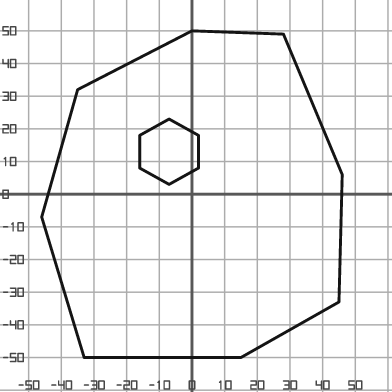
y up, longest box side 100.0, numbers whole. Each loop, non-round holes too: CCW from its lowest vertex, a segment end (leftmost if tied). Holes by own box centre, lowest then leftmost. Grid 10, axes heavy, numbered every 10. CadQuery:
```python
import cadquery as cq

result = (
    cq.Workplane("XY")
    .moveTo(-33.0, -50.0)
    .lineTo(15.0, -50.0)
    .lineTo(45.0, -33.0)
    .lineTo(46.0, 6.0)
    .lineTo(28.0, 49.0)
    .lineTo(0.0, 50.0)
    .lineTo(-35.0, 32.0)
    .lineTo(-46.0, -7.0)
    .close()
    .moveTo(-7.0, 3.0)
    .lineTo(2.0, 8.0)
    .lineTo(2.0, 18.0)
    .lineTo(-7.0, 23.0)
    .lineTo(-16.0, 18.0)
    .lineTo(-16.0, 8.0)
    .close()
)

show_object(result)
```